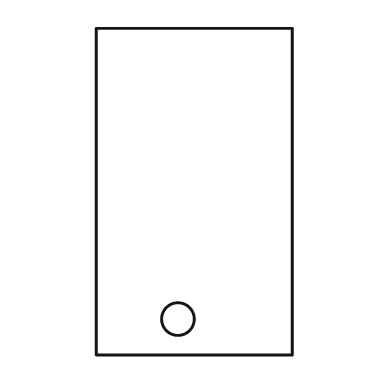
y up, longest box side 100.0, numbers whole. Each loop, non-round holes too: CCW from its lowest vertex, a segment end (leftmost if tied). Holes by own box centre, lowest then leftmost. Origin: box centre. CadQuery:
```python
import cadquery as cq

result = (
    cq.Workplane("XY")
    .moveTo(-30.0, -50.0)
    .lineTo(30.0, -50.0)
    .lineTo(30.0, 50.0)
    .lineTo(-30.0, 50.0)
    .close()
    .moveTo(-5.0, -39.0)
    .circle(5.0)
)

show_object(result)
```